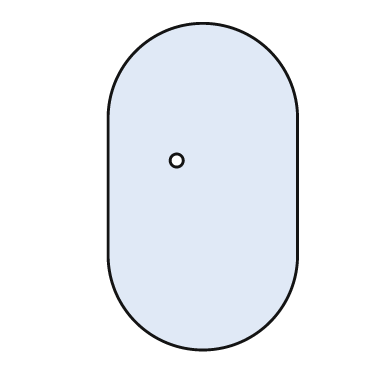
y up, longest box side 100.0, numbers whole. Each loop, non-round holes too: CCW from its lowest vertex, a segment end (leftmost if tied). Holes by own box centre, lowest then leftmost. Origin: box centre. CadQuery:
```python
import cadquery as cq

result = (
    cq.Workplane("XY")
    .moveTo(-29.0, -21.0)
    .threePointArc((0.0, -50.0), (29.0, -21.0))
    .lineTo(29.0, 21.0)
    .threePointArc((0.0, 50.0), (-29.0, 21.0))
    .close()
    .moveTo(-8.0, 8.0)
    .circle(2.0)
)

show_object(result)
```